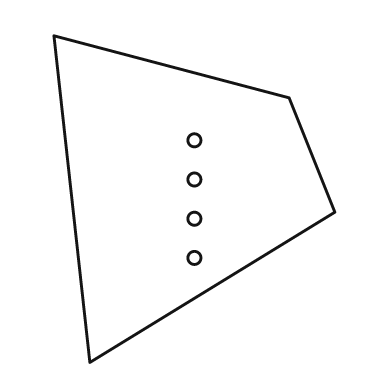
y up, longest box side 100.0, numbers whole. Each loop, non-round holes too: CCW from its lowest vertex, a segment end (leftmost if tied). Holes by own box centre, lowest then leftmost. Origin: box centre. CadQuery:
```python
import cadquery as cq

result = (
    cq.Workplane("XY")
    .moveTo(-32.0, -50.0)
    .lineTo(43.0, -4.0)
    .lineTo(29.0, 31.0)
    .lineTo(-43.0, 50.0)
    .close()
    .moveTo(0.0, -18.0)
    .circle(2.0)
    .moveTo(0.0, -6.0)
    .circle(2.0)
    .moveTo(0.0, 6.0)
    .circle(2.0)
    .moveTo(0.0, 18.0)
    .circle(2.0)
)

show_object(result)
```